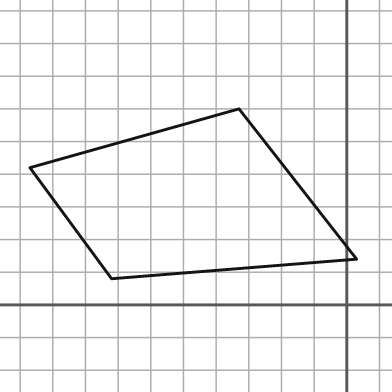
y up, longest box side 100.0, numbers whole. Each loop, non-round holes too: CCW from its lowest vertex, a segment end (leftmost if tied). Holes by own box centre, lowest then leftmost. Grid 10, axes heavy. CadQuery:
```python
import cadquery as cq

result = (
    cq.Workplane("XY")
    .moveTo(-72.0, 8.0)
    .lineTo(3.0, 14.0)
    .lineTo(-33.0, 60.0)
    .lineTo(-97.0, 42.0)
    .close()
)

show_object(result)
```